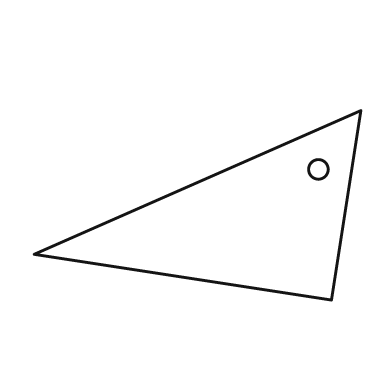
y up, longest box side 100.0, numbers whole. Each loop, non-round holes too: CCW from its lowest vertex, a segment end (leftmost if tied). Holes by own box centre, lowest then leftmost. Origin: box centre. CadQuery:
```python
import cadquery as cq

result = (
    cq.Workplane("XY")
    .moveTo(41.0, -29.0)
    .lineTo(50.0, 29.0)
    .lineTo(-50.0, -15.0)
    .close()
    .moveTo(37.0, 11.0)
    .circle(3.0)
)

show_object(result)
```